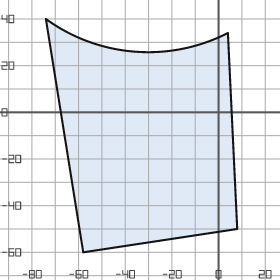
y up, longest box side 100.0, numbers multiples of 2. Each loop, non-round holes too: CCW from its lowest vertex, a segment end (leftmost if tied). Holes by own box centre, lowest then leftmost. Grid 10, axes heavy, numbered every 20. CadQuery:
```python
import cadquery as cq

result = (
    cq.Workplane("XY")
    .moveTo(-58.0, -60.0)
    .lineTo(8.0, -50.0)
    .lineTo(4.0, 34.0)
    .threePointArc((-36.0, 26.0), (-74.0, 40.0))
    .close()
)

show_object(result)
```